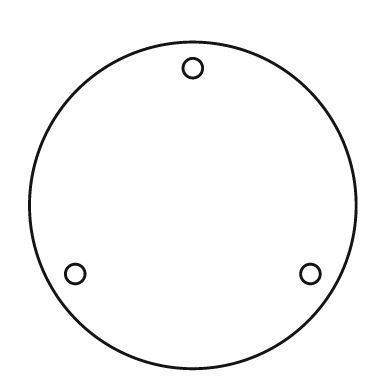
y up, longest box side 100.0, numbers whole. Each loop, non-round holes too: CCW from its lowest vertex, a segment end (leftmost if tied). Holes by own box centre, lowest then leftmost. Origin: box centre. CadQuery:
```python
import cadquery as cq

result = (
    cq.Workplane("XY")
    .moveTo(0.0, 0.0)
    .circle(50.0)
    .moveTo(-36.0, -21.0)
    .circle(3.0)
    .moveTo(36.0, -21.0)
    .circle(3.0)
    .moveTo(0.0, 42.0)
    .circle(3.0)
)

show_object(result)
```